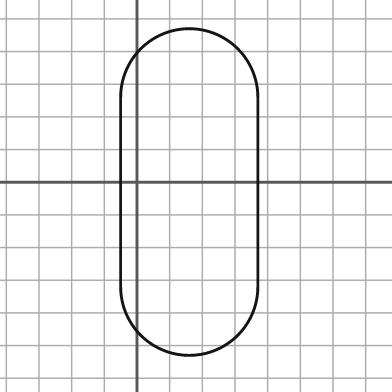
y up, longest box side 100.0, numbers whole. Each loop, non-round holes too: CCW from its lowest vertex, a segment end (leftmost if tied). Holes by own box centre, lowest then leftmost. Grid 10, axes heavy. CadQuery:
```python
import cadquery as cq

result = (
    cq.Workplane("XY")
    .moveTo(-5.0, -32.0)
    .threePointArc((16.0, -53.0), (37.0, -32.0))
    .lineTo(37.0, 26.0)
    .threePointArc((16.0, 47.0), (-5.0, 26.0))
    .close()
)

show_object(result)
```